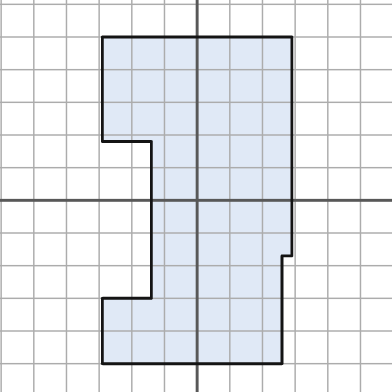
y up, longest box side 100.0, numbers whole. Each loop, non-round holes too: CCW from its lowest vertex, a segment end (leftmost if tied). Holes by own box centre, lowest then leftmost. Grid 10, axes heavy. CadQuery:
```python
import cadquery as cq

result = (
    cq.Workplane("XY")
    .moveTo(-29.0, -50.0)
    .lineTo(26.0, -50.0)
    .lineTo(26.0, -17.0)
    .lineTo(29.0, -17.0)
    .lineTo(29.0, 50.0)
    .lineTo(-29.0, 50.0)
    .lineTo(-29.0, 18.0)
    .lineTo(-14.0, 18.0)
    .lineTo(-14.0, -30.0)
    .lineTo(-29.0, -30.0)
    .close()
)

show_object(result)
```